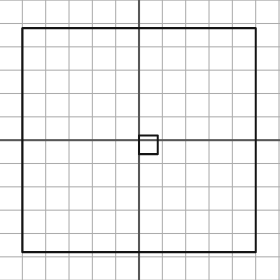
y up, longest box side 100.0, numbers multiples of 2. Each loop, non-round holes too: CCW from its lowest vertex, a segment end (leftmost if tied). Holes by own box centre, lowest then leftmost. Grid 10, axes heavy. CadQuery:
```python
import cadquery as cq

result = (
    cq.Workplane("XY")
    .moveTo(-50.0, -48.0)
    .lineTo(50.0, -48.0)
    .lineTo(50.0, 48.0)
    .lineTo(-50.0, 48.0)
    .close()
    .moveTo(0.0, -6.0)
    .lineTo(8.0, -6.0)
    .lineTo(8.0, 2.0)
    .lineTo(0.0, 2.0)
    .close()
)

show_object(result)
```